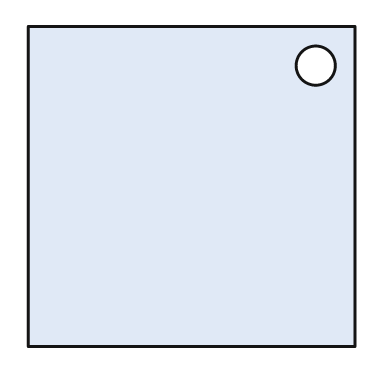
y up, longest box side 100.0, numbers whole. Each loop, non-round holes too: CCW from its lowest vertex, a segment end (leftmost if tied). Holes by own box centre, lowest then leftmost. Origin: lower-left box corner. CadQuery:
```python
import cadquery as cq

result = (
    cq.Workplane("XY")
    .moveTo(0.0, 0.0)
    .lineTo(100.0, 0.0)
    .lineTo(100.0, 98.0)
    .lineTo(0.0, 98.0)
    .close()
    .moveTo(88.0, 86.0)
    .circle(6.0)
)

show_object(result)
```